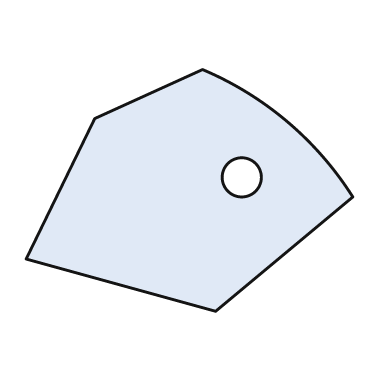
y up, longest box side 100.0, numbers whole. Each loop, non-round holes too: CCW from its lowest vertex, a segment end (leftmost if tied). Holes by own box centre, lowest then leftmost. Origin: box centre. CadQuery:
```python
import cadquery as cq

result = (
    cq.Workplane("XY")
    .moveTo(8.0, -37.0)
    .lineTo(50.0, -2.0)
    .threePointArc((30.0, 21.0), (4.0, 37.0))
    .lineTo(-29.0, 22.0)
    .lineTo(-50.0, -21.0)
    .close()
    .moveTo(16.0, 4.0)
    .circle(6.0)
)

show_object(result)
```